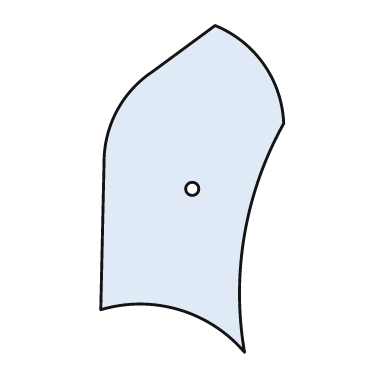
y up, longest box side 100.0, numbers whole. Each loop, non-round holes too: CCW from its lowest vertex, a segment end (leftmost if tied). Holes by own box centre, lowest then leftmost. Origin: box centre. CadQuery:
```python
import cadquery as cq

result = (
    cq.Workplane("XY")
    .moveTo(16.0, -50.0)
    .threePointArc((16.0, -14.0), (28.0, 20.0))
    .threePointArc((22.0, 38.0), (7.0, 50.0))
    .lineTo(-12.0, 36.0)
    .threePointArc((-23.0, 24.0), (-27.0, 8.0))
    .lineTo(-28.0, -37.0)
    .threePointArc((-4.0, -37.0), (16.0, -50.0))
    .close()
    .moveTo(0.0, 0.0)
    .circle(2.0)
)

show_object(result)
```